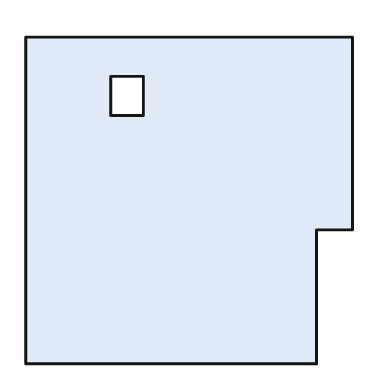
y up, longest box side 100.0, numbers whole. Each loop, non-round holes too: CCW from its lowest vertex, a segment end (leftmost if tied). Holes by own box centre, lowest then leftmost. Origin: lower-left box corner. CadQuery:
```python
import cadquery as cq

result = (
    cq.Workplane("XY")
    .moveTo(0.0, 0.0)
    .lineTo(89.0, 0.0)
    .lineTo(89.0, 41.0)
    .lineTo(100.0, 41.0)
    .lineTo(100.0, 100.0)
    .lineTo(0.0, 100.0)
    .close()
    .moveTo(26.0, 76.0)
    .lineTo(36.0, 76.0)
    .lineTo(36.0, 88.0)
    .lineTo(26.0, 88.0)
    .close()
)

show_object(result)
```